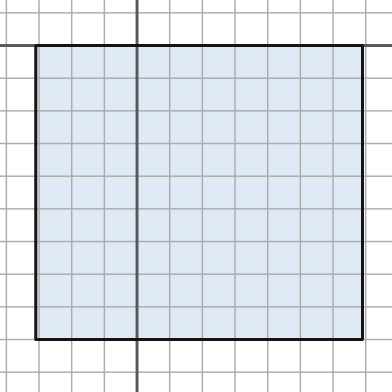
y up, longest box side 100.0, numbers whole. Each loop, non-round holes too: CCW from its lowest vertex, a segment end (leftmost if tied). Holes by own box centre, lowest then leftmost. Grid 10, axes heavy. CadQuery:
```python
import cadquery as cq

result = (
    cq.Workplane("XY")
    .moveTo(-31.0, -90.0)
    .lineTo(69.0, -90.0)
    .lineTo(69.0, 0.0)
    .lineTo(-31.0, 0.0)
    .close()
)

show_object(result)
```